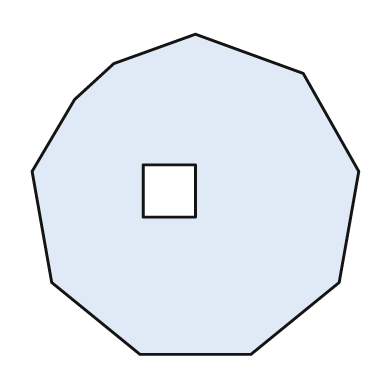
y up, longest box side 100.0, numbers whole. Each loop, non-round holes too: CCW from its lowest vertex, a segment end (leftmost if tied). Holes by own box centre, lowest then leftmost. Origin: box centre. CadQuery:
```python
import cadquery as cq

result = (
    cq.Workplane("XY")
    .moveTo(-17.0, -49.0)
    .lineTo(17.0, -49.0)
    .lineTo(44.0, -27.0)
    .lineTo(50.0, 7.0)
    .lineTo(33.0, 37.0)
    .lineTo(0.0, 49.0)
    .lineTo(-25.0, 40.0)
    .lineTo(-37.0, 29.0)
    .lineTo(-50.0, 7.0)
    .lineTo(-44.0, -27.0)
    .close()
    .moveTo(-16.0, -7.0)
    .lineTo(0.0, -7.0)
    .lineTo(0.0, 9.0)
    .lineTo(-16.0, 9.0)
    .close()
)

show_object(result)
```